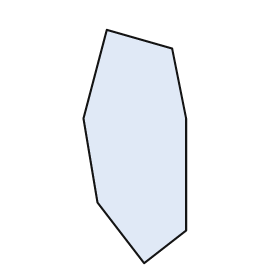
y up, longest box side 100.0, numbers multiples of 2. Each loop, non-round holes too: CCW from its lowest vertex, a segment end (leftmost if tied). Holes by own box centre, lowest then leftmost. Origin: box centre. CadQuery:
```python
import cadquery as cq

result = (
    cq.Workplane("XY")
    .moveTo(4.0, -50.0)
    .lineTo(22.0, -36.0)
    .lineTo(22.0, 12.0)
    .lineTo(16.0, 42.0)
    .lineTo(-12.0, 50.0)
    .lineTo(-22.0, 12.0)
    .lineTo(-16.0, -24.0)
    .close()
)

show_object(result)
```